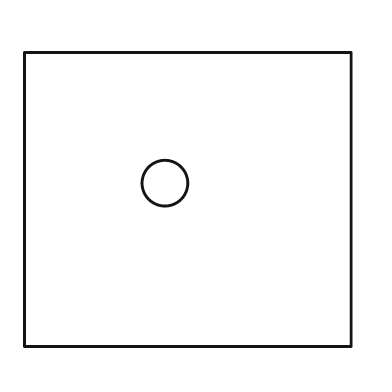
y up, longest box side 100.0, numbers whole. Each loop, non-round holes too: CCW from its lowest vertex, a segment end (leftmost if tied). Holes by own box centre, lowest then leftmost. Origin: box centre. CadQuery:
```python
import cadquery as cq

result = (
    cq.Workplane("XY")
    .moveTo(-50.0, -45.0)
    .lineTo(50.0, -45.0)
    .lineTo(50.0, 45.0)
    .lineTo(-50.0, 45.0)
    .close()
    .moveTo(-7.0, 5.0)
    .circle(7.0)
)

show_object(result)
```